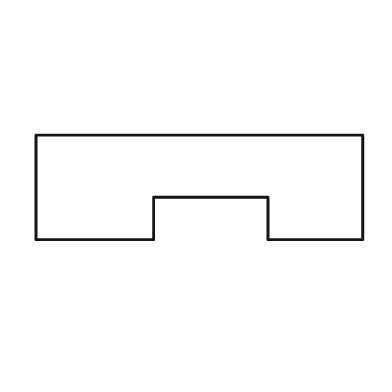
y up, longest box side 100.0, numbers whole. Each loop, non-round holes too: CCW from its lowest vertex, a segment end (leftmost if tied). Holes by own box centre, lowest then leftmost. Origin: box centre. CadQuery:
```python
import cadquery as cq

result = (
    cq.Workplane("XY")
    .moveTo(-50.0, -16.0)
    .lineTo(-14.0, -16.0)
    .lineTo(-14.0, -3.0)
    .lineTo(21.0, -3.0)
    .lineTo(21.0, -16.0)
    .lineTo(50.0, -16.0)
    .lineTo(50.0, 16.0)
    .lineTo(-50.0, 16.0)
    .close()
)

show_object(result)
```